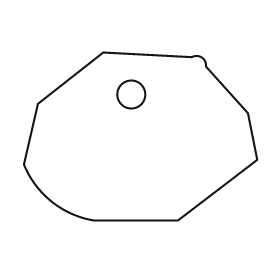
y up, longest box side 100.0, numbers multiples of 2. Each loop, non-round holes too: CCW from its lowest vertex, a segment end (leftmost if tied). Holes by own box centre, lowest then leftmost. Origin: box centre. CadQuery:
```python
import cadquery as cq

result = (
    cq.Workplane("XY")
    .moveTo(-20.0, -36.0)
    .lineTo(16.0, -36.0)
    .lineTo(50.0, -10.0)
    .lineTo(46.0, 10.0)
    .lineTo(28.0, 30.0)
    .threePointArc((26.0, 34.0), (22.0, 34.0))
    .lineTo(-16.0, 36.0)
    .lineTo(-44.0, 14.0)
    .lineTo(-50.0, -12.0)
    .threePointArc((-38.0, -28.0), (-20.0, -36.0))
    .close()
    .moveTo(-4.0, 18.0)
    .circle(6.0)
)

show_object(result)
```